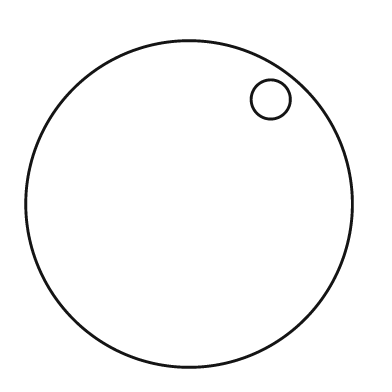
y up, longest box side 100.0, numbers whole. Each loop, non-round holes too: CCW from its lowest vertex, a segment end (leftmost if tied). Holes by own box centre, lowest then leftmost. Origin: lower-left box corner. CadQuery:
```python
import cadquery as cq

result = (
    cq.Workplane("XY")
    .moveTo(50.0, 50.0)
    .circle(50.0)
    .moveTo(75.0, 82.0)
    .circle(6.0)
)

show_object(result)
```